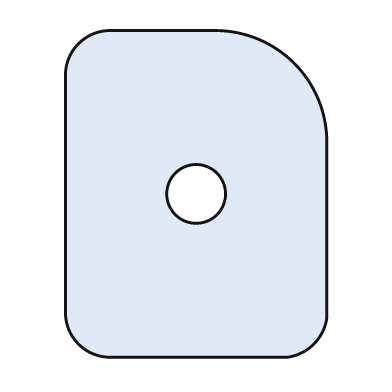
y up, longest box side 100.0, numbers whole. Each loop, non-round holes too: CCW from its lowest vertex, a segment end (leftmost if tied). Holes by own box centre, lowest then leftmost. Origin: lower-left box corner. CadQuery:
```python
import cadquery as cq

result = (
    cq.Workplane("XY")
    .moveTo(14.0, 0.0)
    .lineTo(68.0, 0.0)
    .threePointArc((76.0, 4.0), (80.0, 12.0))
    .lineTo(80.0, 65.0)
    .threePointArc((70.0, 90.0), (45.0, 100.0))
    .lineTo(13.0, 100.0)
    .threePointArc((4.0, 96.0), (0.0, 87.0))
    .lineTo(0.0, 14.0)
    .threePointArc((4.0, 4.0), (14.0, 0.0))
    .close()
    .moveTo(40.0, 50.0)
    .circle(9.0)
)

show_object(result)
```